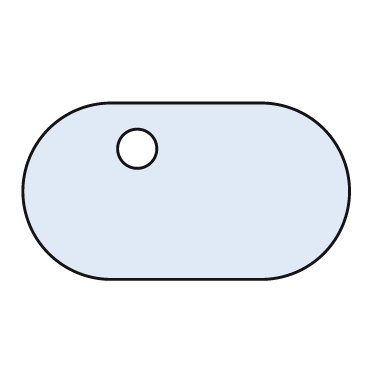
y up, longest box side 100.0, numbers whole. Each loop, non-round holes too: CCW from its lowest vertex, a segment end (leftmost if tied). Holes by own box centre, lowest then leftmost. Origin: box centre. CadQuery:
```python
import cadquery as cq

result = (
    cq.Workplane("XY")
    .moveTo(-23.0, -27.0)
    .lineTo(23.0, -27.0)
    .threePointArc((50.0, 0.0), (23.0, 27.0))
    .lineTo(-23.0, 27.0)
    .threePointArc((-50.0, 0.0), (-23.0, -27.0))
    .close()
    .moveTo(-15.0, 13.0)
    .circle(6.0)
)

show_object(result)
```